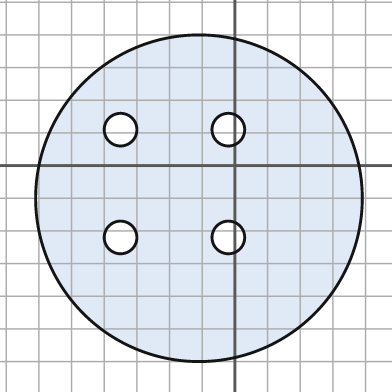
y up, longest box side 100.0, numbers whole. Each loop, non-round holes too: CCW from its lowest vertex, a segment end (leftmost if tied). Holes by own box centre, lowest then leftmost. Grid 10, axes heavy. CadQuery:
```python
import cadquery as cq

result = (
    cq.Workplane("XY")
    .moveTo(-11.0, -10.0)
    .circle(50.0)
    .moveTo(-35.0, -22.0)
    .circle(5.0)
    .moveTo(-2.0, -22.0)
    .circle(5.0)
    .moveTo(-35.0, 11.0)
    .circle(5.0)
    .moveTo(-2.0, 11.0)
    .circle(5.0)
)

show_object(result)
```